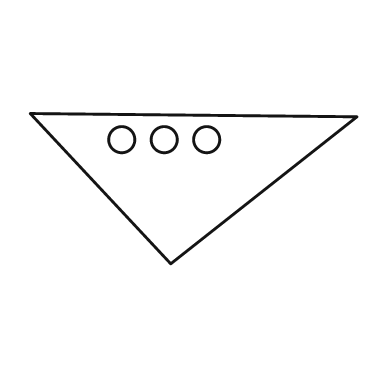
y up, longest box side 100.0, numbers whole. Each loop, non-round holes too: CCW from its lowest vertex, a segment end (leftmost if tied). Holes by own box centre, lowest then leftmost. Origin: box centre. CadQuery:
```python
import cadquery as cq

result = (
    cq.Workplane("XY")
    .moveTo(-7.0, -23.0)
    .lineTo(50.0, 22.0)
    .lineTo(-50.0, 23.0)
    .close()
    .moveTo(-22.0, 15.0)
    .circle(4.0)
    .moveTo(-9.0, 15.0)
    .circle(4.0)
    .moveTo(4.0, 15.0)
    .circle(4.0)
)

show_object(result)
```